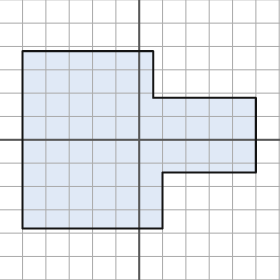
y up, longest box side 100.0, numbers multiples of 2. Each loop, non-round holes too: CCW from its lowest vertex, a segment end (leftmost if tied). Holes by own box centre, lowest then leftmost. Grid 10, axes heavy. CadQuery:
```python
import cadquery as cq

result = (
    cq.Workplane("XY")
    .moveTo(-50.0, -38.0)
    .lineTo(10.0, -38.0)
    .lineTo(10.0, -14.0)
    .lineTo(50.0, -14.0)
    .lineTo(50.0, 18.0)
    .lineTo(6.0, 18.0)
    .lineTo(6.0, 38.0)
    .lineTo(-50.0, 38.0)
    .close()
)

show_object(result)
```